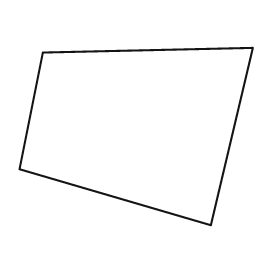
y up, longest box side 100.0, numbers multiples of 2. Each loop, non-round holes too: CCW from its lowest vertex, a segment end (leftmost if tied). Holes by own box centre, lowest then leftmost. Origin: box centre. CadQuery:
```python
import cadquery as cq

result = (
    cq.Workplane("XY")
    .moveTo(32.0, -38.0)
    .lineTo(50.0, 38.0)
    .lineTo(-40.0, 36.0)
    .lineTo(-50.0, -14.0)
    .close()
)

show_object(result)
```